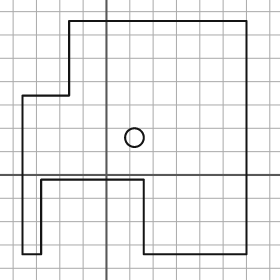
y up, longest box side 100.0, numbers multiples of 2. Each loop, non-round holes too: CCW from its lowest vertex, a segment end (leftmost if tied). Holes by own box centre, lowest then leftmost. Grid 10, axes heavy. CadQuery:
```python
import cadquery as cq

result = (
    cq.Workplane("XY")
    .moveTo(-36.0, -34.0)
    .lineTo(-28.0, -34.0)
    .lineTo(-28.0, -2.0)
    .lineTo(16.0, -2.0)
    .lineTo(16.0, -34.0)
    .lineTo(60.0, -34.0)
    .lineTo(60.0, 66.0)
    .lineTo(-16.0, 66.0)
    .lineTo(-16.0, 34.0)
    .lineTo(-36.0, 34.0)
    .close()
    .moveTo(12.0, 16.0)
    .circle(4.0)
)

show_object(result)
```